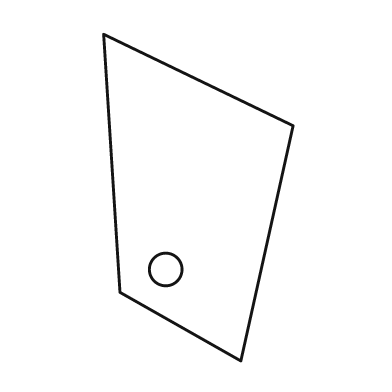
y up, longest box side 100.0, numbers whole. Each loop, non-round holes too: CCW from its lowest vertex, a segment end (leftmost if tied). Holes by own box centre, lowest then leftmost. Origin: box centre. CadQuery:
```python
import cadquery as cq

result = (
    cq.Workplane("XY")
    .moveTo(13.0, -50.0)
    .lineTo(29.0, 22.0)
    .lineTo(-29.0, 50.0)
    .lineTo(-24.0, -29.0)
    .close()
    .moveTo(-10.0, -22.0)
    .circle(5.0)
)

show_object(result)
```